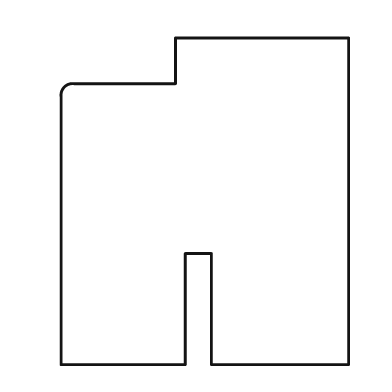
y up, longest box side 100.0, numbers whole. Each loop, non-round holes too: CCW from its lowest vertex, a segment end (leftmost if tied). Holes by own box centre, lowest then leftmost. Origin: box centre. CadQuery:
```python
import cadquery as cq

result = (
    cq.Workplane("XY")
    .moveTo(-44.0, -50.0)
    .lineTo(-6.0, -50.0)
    .lineTo(-6.0, -16.0)
    .lineTo(2.0, -16.0)
    .lineTo(2.0, -50.0)
    .lineTo(44.0, -50.0)
    .lineTo(44.0, 50.0)
    .lineTo(-9.0, 50.0)
    .lineTo(-9.0, 36.0)
    .lineTo(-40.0, 36.0)
    .threePointArc((-43.0, 35.0), (-44.0, 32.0))
    .close()
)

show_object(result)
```